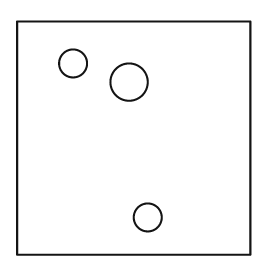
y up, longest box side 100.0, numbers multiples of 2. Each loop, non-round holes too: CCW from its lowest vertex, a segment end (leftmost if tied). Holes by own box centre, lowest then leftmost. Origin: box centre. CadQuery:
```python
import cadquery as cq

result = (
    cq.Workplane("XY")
    .moveTo(-50.0, -50.0)
    .lineTo(50.0, -50.0)
    .lineTo(50.0, 50.0)
    .lineTo(-50.0, 50.0)
    .close()
    .moveTo(6.0, -34.0)
    .circle(6.0)
    .moveTo(-2.0, 24.0)
    .circle(8.0)
    .moveTo(-26.0, 32.0)
    .circle(6.0)
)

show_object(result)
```